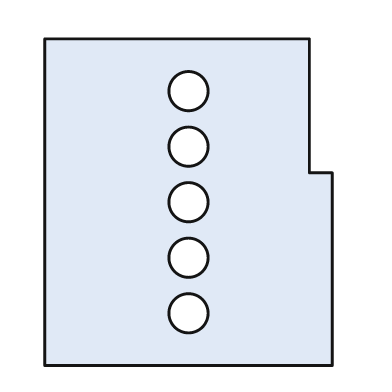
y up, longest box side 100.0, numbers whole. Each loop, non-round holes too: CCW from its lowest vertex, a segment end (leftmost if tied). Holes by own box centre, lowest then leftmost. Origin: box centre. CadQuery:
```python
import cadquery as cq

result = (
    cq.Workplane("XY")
    .moveTo(-44.0, -50.0)
    .lineTo(44.0, -50.0)
    .lineTo(44.0, 9.0)
    .lineTo(37.0, 9.0)
    .lineTo(37.0, 50.0)
    .lineTo(-44.0, 50.0)
    .close()
    .moveTo(0.0, -34.0)
    .circle(6.0)
    .moveTo(0.0, -17.0)
    .circle(6.0)
    .moveTo(0.0, 0.0)
    .circle(6.0)
    .moveTo(0.0, 17.0)
    .circle(6.0)
    .moveTo(0.0, 34.0)
    .circle(6.0)
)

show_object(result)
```